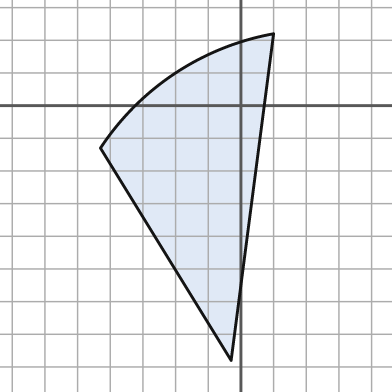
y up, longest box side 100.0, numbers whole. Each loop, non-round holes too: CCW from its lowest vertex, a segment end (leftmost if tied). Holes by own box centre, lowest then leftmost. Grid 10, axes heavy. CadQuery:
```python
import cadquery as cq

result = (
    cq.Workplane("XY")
    .moveTo(-3.0, -78.0)
    .lineTo(10.0, 22.0)
    .threePointArc((-20.0, 10.0), (-43.0, -13.0))
    .close()
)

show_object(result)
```